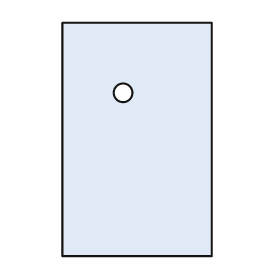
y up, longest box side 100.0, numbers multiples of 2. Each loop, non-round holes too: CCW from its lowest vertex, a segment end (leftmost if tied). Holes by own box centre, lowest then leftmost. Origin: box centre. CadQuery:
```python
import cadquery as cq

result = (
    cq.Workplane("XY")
    .moveTo(-32.0, -50.0)
    .lineTo(32.0, -50.0)
    .lineTo(32.0, 50.0)
    .lineTo(-32.0, 50.0)
    .close()
    .moveTo(-6.0, 20.0)
    .circle(4.0)
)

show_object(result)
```